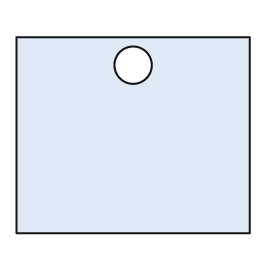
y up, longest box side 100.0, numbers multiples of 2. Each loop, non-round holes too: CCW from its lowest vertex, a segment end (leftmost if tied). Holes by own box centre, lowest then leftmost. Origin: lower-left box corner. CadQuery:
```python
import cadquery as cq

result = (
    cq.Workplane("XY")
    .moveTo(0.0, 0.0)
    .lineTo(100.0, 0.0)
    .lineTo(100.0, 84.0)
    .lineTo(0.0, 84.0)
    .close()
    .moveTo(50.0, 72.0)
    .circle(8.0)
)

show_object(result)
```